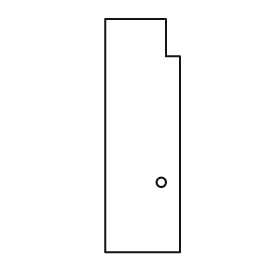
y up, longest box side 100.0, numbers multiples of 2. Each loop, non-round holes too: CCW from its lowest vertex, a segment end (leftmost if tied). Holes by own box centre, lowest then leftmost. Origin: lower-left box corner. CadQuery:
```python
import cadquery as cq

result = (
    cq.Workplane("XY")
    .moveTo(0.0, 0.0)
    .lineTo(32.0, 0.0)
    .lineTo(32.0, 84.0)
    .lineTo(26.0, 84.0)
    .lineTo(26.0, 100.0)
    .lineTo(0.0, 100.0)
    .close()
    .moveTo(24.0, 30.0)
    .circle(2.0)
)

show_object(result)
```